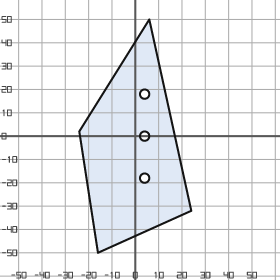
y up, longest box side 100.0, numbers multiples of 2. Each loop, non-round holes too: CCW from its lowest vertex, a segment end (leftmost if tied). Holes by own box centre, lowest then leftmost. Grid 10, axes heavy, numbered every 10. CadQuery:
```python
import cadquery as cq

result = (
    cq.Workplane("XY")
    .moveTo(-16.0, -50.0)
    .lineTo(24.0, -32.0)
    .lineTo(6.0, 50.0)
    .lineTo(-24.0, 2.0)
    .close()
    .moveTo(4.0, -18.0)
    .circle(2.0)
    .moveTo(4.0, 0.0)
    .circle(2.0)
    .moveTo(4.0, 18.0)
    .circle(2.0)
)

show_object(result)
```